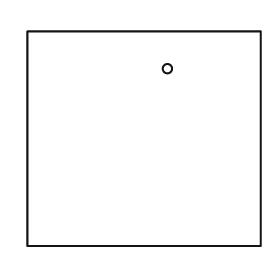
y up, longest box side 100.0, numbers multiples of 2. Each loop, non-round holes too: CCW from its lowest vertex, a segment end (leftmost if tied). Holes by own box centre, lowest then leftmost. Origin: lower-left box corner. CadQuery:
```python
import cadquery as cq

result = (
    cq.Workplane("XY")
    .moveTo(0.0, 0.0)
    .lineTo(100.0, 0.0)
    .lineTo(100.0, 92.0)
    .lineTo(0.0, 92.0)
    .close()
    .moveTo(60.0, 76.0)
    .circle(2.0)
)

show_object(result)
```